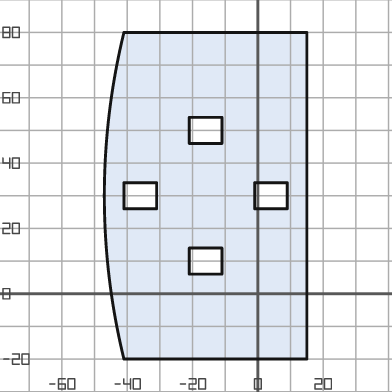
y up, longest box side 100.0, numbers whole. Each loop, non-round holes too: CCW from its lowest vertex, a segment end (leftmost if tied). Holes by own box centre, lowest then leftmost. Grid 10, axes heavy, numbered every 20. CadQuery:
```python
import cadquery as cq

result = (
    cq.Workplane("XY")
    .moveTo(-41.0, -20.0)
    .lineTo(15.0, -20.0)
    .lineTo(15.0, 80.0)
    .lineTo(-41.0, 80.0)
    .threePointArc((-47.0, 30.0), (-41.0, -20.0))
    .close()
    .moveTo(-21.0, 6.0)
    .lineTo(-11.0, 6.0)
    .lineTo(-11.0, 14.0)
    .lineTo(-21.0, 14.0)
    .close()
    .moveTo(-41.0, 26.0)
    .lineTo(-31.0, 26.0)
    .lineTo(-31.0, 34.0)
    .lineTo(-41.0, 34.0)
    .close()
    .moveTo(-1.0, 26.0)
    .lineTo(9.0, 26.0)
    .lineTo(9.0, 34.0)
    .lineTo(-1.0, 34.0)
    .close()
    .moveTo(-21.0, 46.0)
    .lineTo(-11.0, 46.0)
    .lineTo(-11.0, 54.0)
    .lineTo(-21.0, 54.0)
    .close()
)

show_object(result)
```